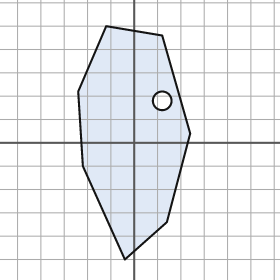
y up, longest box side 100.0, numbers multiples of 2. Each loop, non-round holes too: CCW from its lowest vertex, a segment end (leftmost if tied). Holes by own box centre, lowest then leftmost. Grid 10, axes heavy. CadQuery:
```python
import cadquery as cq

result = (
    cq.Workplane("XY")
    .moveTo(-4.0, -50.0)
    .lineTo(14.0, -34.0)
    .lineTo(24.0, 4.0)
    .lineTo(12.0, 46.0)
    .lineTo(-12.0, 50.0)
    .lineTo(-24.0, 22.0)
    .lineTo(-22.0, -10.0)
    .close()
    .moveTo(12.0, 18.0)
    .circle(4.0)
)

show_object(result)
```